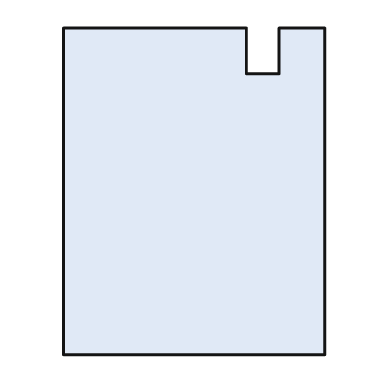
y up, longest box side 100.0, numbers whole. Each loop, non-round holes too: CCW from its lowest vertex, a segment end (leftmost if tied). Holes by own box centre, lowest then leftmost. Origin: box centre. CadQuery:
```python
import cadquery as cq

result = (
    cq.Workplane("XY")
    .moveTo(-40.0, -50.0)
    .lineTo(40.0, -50.0)
    .lineTo(40.0, 50.0)
    .lineTo(26.0, 50.0)
    .lineTo(26.0, 36.0)
    .lineTo(16.0, 36.0)
    .lineTo(16.0, 50.0)
    .lineTo(-40.0, 50.0)
    .close()
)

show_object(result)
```